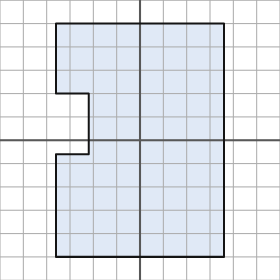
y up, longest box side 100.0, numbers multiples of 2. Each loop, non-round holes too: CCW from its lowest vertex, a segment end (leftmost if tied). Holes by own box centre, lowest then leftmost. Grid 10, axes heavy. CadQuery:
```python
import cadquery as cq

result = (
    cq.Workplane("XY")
    .moveTo(-36.0, -50.0)
    .lineTo(36.0, -50.0)
    .lineTo(36.0, 50.0)
    .lineTo(-36.0, 50.0)
    .lineTo(-36.0, 20.0)
    .lineTo(-22.0, 20.0)
    .lineTo(-22.0, -6.0)
    .lineTo(-36.0, -6.0)
    .close()
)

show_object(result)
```